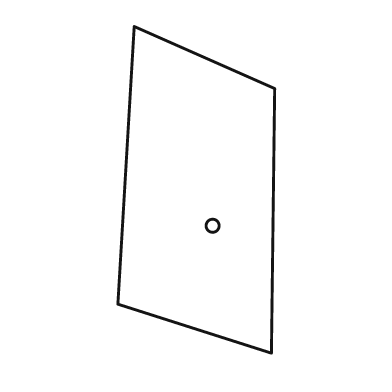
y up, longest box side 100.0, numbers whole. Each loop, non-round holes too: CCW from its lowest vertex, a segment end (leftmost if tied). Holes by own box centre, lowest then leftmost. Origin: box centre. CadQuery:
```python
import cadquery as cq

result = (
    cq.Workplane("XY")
    .moveTo(23.0, -50.0)
    .lineTo(24.0, 31.0)
    .lineTo(-19.0, 50.0)
    .lineTo(-24.0, -35.0)
    .close()
    .moveTo(5.0, -11.0)
    .circle(2.0)
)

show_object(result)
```